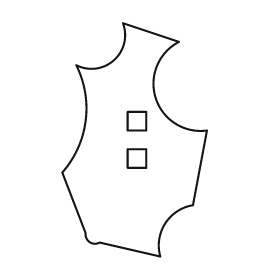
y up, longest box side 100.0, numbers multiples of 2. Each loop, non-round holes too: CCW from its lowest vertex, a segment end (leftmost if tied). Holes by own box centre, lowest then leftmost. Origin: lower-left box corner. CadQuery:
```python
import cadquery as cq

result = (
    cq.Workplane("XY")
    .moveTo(42.0, 0.0)
    .threePointArc((44.0, 14.0), (56.0, 22.0))
    .lineTo(62.0, 54.0)
    .threePointArc((40.0, 68.0), (50.0, 92.0))
    .lineTo(26.0, 100.0)
    .threePointArc((22.0, 84.0), (6.0, 82.0))
    .threePointArc((10.0, 58.0), (0.0, 36.0))
    .lineTo(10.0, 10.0)
    .threePointArc((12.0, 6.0), (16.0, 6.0))
    .close()
    .moveTo(28.0, 38.0)
    .lineTo(36.0, 38.0)
    .lineTo(36.0, 46.0)
    .lineTo(28.0, 46.0)
    .close()
    .moveTo(28.0, 54.0)
    .lineTo(36.0, 54.0)
    .lineTo(36.0, 62.0)
    .lineTo(28.0, 62.0)
    .close()
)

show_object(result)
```